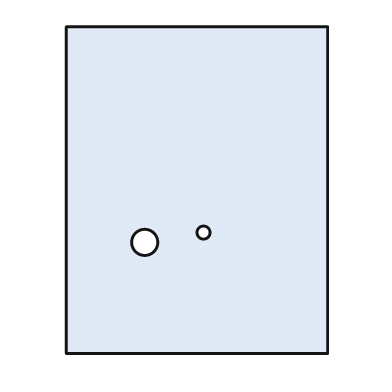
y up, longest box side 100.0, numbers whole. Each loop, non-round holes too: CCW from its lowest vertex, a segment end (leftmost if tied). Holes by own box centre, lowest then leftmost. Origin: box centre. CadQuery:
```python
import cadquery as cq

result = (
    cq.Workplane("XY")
    .moveTo(-40.0, -50.0)
    .lineTo(40.0, -50.0)
    .lineTo(40.0, 50.0)
    .lineTo(-40.0, 50.0)
    .close()
    .moveTo(-16.0, -16.0)
    .circle(4.0)
    .moveTo(2.0, -13.0)
    .circle(2.0)
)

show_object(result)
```